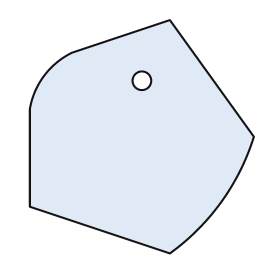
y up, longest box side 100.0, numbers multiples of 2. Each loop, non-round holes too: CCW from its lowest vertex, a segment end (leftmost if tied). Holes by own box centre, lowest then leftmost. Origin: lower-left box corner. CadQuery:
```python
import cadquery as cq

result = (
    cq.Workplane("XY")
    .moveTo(60.0, 0.0)
    .threePointArc((82.0, 22.0), (96.0, 50.0))
    .lineTo(60.0, 100.0)
    .lineTo(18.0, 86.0)
    .threePointArc((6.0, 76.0), (0.0, 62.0))
    .lineTo(0.0, 20.0)
    .close()
    .moveTo(48.0, 74.0)
    .circle(4.0)
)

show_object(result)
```